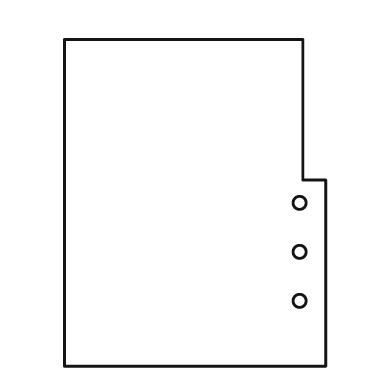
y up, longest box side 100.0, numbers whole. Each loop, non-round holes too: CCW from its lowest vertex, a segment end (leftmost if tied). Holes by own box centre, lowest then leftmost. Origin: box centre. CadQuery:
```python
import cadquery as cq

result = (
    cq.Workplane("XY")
    .moveTo(-40.0, -50.0)
    .lineTo(40.0, -50.0)
    .lineTo(40.0, 7.0)
    .lineTo(33.0, 7.0)
    .lineTo(33.0, 50.0)
    .lineTo(-40.0, 50.0)
    .close()
    .moveTo(32.0, -30.0)
    .circle(2.0)
    .moveTo(32.0, -15.0)
    .circle(2.0)
    .moveTo(32.0, 0.0)
    .circle(2.0)
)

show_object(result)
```